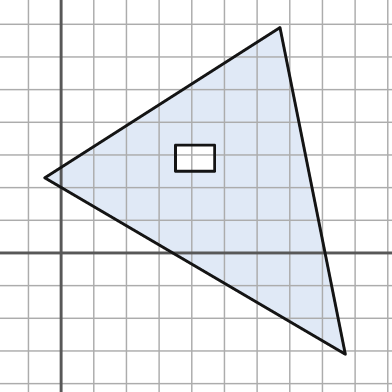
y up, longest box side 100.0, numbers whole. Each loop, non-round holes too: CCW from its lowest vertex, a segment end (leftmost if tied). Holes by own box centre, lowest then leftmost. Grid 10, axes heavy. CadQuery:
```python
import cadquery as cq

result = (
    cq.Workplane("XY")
    .moveTo(87.0, -31.0)
    .lineTo(67.0, 69.0)
    .lineTo(-5.0, 23.0)
    .close()
    .moveTo(35.0, 25.0)
    .lineTo(47.0, 25.0)
    .lineTo(47.0, 33.0)
    .lineTo(35.0, 33.0)
    .close()
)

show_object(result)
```